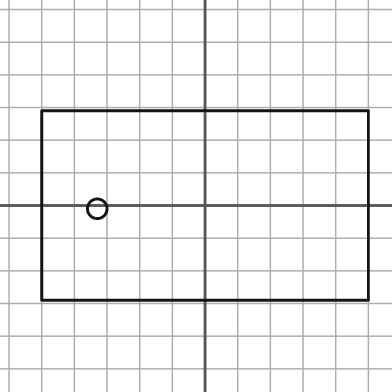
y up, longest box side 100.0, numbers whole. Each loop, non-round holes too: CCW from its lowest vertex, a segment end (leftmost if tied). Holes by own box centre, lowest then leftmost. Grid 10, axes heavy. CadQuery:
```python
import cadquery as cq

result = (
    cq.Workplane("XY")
    .moveTo(-50.0, -29.0)
    .lineTo(50.0, -29.0)
    .lineTo(50.0, 29.0)
    .lineTo(-50.0, 29.0)
    .close()
    .moveTo(-33.0, -1.0)
    .circle(3.0)
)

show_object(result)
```